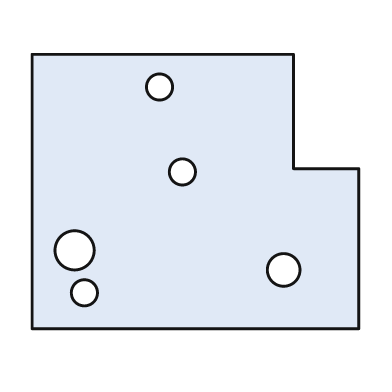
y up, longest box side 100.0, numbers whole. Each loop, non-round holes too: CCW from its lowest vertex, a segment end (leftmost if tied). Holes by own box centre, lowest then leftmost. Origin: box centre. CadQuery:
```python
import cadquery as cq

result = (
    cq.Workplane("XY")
    .moveTo(-50.0, -42.0)
    .lineTo(50.0, -42.0)
    .lineTo(50.0, 7.0)
    .lineTo(30.0, 7.0)
    .lineTo(30.0, 42.0)
    .lineTo(-50.0, 42.0)
    .close()
    .moveTo(-34.0, -31.0)
    .circle(4.0)
    .moveTo(27.0, -24.0)
    .circle(5.0)
    .moveTo(-37.0, -18.0)
    .circle(6.0)
    .moveTo(-4.0, 6.0)
    .circle(4.0)
    .moveTo(-11.0, 32.0)
    .circle(4.0)
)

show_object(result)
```